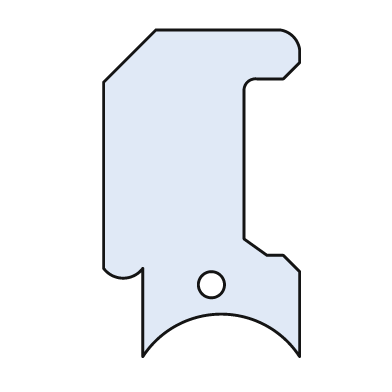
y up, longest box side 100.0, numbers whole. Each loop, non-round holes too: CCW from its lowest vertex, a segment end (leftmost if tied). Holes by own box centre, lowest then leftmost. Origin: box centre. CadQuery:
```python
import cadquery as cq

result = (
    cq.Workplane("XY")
    .moveTo(-18.0, -50.0)
    .threePointArc((6.0, -37.0), (30.0, -50.0))
    .lineTo(30.0, -24.0)
    .lineTo(25.0, -19.0)
    .lineTo(20.0, -19.0)
    .lineTo(13.0, -14.0)
    .lineTo(13.0, 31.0)
    .threePointArc((14.0, 34.0), (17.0, 35.0))
    .lineTo(25.0, 35.0)
    .lineTo(30.0, 40.0)
    .lineTo(30.0, 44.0)
    .threePointArc((28.0, 48.0), (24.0, 50.0))
    .lineTo(-14.0, 50.0)
    .lineTo(-30.0, 34.0)
    .lineTo(-30.0, -23.0)
    .threePointArc((-24.0, -26.0), (-18.0, -23.0))
    .close()
    .moveTo(3.0, -28.0)
    .circle(4.0)
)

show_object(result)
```